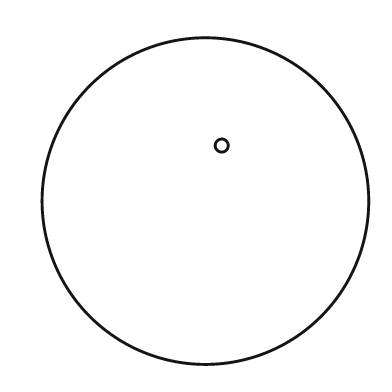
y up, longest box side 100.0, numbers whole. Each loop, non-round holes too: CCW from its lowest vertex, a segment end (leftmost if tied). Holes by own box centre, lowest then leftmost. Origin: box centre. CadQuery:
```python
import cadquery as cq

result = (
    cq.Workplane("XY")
    .moveTo(0.0, 0.0)
    .circle(50.0)
    .moveTo(5.0, 17.0)
    .circle(2.0)
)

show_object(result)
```